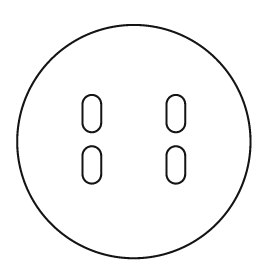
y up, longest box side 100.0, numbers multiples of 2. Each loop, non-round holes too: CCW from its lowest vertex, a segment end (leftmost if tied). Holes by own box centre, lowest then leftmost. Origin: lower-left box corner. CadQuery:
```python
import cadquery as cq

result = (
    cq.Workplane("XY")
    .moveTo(50.0, 50.0)
    .circle(50.0)
    .moveTo(28.0, 36.0)
    .threePointArc((32.0, 32.0), (36.0, 36.0))
    .lineTo(36.0, 44.0)
    .threePointArc((32.0, 48.0), (28.0, 44.0))
    .close()
    .moveTo(64.0, 36.0)
    .threePointArc((68.0, 32.0), (72.0, 36.0))
    .lineTo(72.0, 44.0)
    .threePointArc((68.0, 48.0), (64.0, 44.0))
    .close()
    .moveTo(28.0, 58.0)
    .threePointArc((32.0, 54.0), (36.0, 58.0))
    .lineTo(36.0, 66.0)
    .threePointArc((32.0, 70.0), (28.0, 66.0))
    .close()
    .moveTo(64.0, 58.0)
    .threePointArc((68.0, 54.0), (72.0, 58.0))
    .lineTo(72.0, 66.0)
    .threePointArc((68.0, 70.0), (64.0, 66.0))
    .close()
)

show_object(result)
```